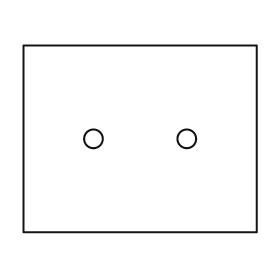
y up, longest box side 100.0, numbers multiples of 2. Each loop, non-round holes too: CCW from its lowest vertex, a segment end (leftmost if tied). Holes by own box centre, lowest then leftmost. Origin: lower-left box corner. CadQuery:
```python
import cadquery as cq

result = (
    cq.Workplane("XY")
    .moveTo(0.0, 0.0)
    .lineTo(100.0, 0.0)
    .lineTo(100.0, 80.0)
    .lineTo(0.0, 80.0)
    .close()
    .moveTo(30.0, 40.0)
    .circle(4.0)
    .moveTo(70.0, 40.0)
    .circle(4.0)
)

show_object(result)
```